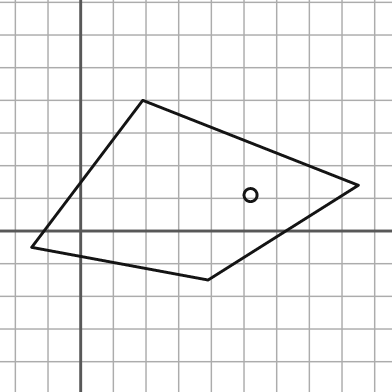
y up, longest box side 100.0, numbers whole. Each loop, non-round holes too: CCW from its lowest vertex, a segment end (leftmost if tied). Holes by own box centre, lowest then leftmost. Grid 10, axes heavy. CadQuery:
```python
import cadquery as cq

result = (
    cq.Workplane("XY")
    .moveTo(39.0, -15.0)
    .lineTo(85.0, 14.0)
    .lineTo(19.0, 40.0)
    .lineTo(-15.0, -5.0)
    .close()
    .moveTo(52.0, 11.0)
    .circle(2.0)
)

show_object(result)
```